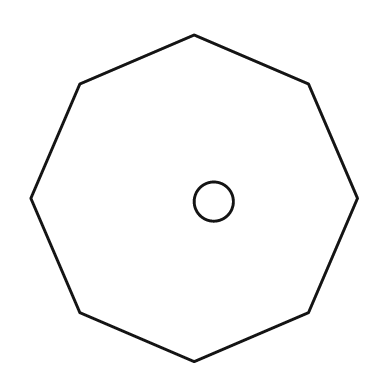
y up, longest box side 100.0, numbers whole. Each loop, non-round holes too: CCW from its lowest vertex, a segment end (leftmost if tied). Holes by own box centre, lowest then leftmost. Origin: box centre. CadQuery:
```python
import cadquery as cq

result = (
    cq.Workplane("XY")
    .moveTo(0.0, -50.0)
    .lineTo(35.0, -35.0)
    .lineTo(50.0, 0.0)
    .lineTo(35.0, 35.0)
    .lineTo(0.0, 50.0)
    .lineTo(-35.0, 35.0)
    .lineTo(-50.0, 0.0)
    .lineTo(-35.0, -35.0)
    .close()
    .moveTo(6.0, -1.0)
    .circle(6.0)
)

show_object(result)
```